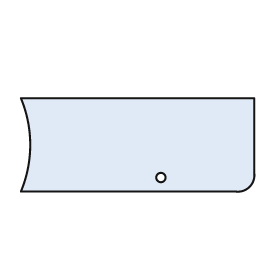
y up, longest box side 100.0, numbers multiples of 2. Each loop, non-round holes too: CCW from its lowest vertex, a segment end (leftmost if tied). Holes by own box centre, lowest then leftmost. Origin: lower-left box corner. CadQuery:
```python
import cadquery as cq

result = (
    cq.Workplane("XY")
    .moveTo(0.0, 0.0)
    .lineTo(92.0, 0.0)
    .threePointArc((98.0, 2.0), (100.0, 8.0))
    .lineTo(100.0, 40.0)
    .lineTo(0.0, 40.0)
    .threePointArc((4.0, 20.0), (0.0, 0.0))
    .close()
    .moveTo(60.0, 6.0)
    .circle(2.0)
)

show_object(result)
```